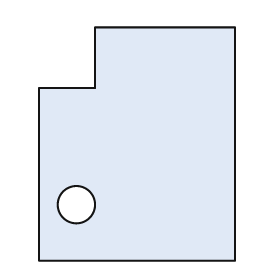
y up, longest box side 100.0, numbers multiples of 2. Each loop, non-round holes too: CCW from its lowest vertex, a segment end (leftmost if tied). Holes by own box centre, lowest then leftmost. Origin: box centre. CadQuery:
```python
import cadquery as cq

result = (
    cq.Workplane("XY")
    .moveTo(-42.0, -50.0)
    .lineTo(42.0, -50.0)
    .lineTo(42.0, 50.0)
    .lineTo(-18.0, 50.0)
    .lineTo(-18.0, 24.0)
    .lineTo(-42.0, 24.0)
    .close()
    .moveTo(-26.0, -26.0)
    .circle(8.0)
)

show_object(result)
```